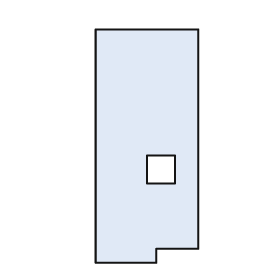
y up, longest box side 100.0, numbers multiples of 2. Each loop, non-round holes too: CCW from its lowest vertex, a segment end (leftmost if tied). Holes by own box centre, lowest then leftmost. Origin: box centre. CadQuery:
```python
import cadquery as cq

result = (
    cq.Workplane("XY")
    .moveTo(-22.0, -50.0)
    .lineTo(4.0, -50.0)
    .lineTo(4.0, -44.0)
    .lineTo(22.0, -44.0)
    .lineTo(22.0, 50.0)
    .lineTo(-22.0, 50.0)
    .close()
    .moveTo(0.0, -16.0)
    .lineTo(12.0, -16.0)
    .lineTo(12.0, -4.0)
    .lineTo(0.0, -4.0)
    .close()
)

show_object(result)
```